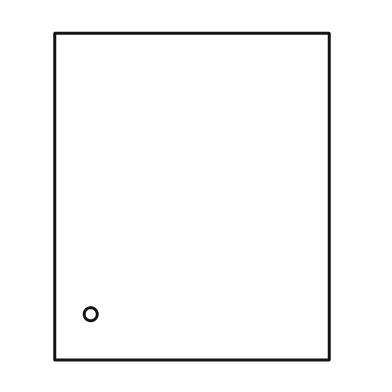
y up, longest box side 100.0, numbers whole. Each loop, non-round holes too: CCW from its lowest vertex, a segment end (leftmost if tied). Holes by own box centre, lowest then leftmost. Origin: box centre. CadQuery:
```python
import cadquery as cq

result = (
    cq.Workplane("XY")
    .moveTo(-42.0, -50.0)
    .lineTo(42.0, -50.0)
    .lineTo(42.0, 50.0)
    .lineTo(-42.0, 50.0)
    .close()
    .moveTo(-31.0, -36.0)
    .circle(2.0)
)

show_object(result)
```